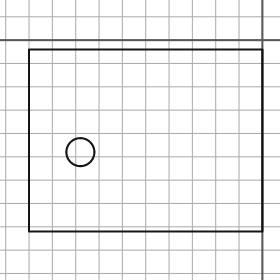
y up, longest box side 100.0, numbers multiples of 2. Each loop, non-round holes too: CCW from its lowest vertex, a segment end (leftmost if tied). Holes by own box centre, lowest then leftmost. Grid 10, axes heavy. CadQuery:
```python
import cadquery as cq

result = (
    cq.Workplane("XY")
    .moveTo(-100.0, -82.0)
    .lineTo(0.0, -82.0)
    .lineTo(0.0, -4.0)
    .lineTo(-100.0, -4.0)
    .close()
    .moveTo(-78.0, -48.0)
    .circle(6.0)
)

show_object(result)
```